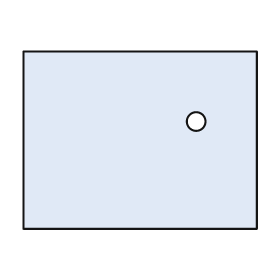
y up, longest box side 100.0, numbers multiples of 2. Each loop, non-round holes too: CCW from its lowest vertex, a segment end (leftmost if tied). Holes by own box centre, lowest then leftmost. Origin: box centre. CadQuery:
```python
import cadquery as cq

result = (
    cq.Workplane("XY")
    .moveTo(-50.0, -38.0)
    .lineTo(50.0, -38.0)
    .lineTo(50.0, 38.0)
    .lineTo(-50.0, 38.0)
    .close()
    .moveTo(24.0, 8.0)
    .circle(4.0)
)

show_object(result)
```